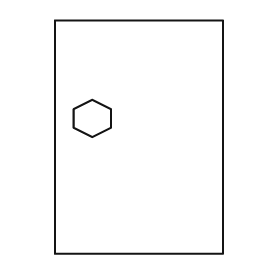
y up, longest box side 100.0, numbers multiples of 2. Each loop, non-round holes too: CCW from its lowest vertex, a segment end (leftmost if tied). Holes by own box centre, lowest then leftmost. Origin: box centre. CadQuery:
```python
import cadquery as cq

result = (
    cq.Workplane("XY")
    .moveTo(-36.0, -50.0)
    .lineTo(36.0, -50.0)
    .lineTo(36.0, 50.0)
    .lineTo(-36.0, 50.0)
    .close()
    .moveTo(-20.0, 0.0)
    .lineTo(-12.0, 4.0)
    .lineTo(-12.0, 12.0)
    .lineTo(-20.0, 16.0)
    .lineTo(-28.0, 12.0)
    .lineTo(-28.0, 4.0)
    .close()
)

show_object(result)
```